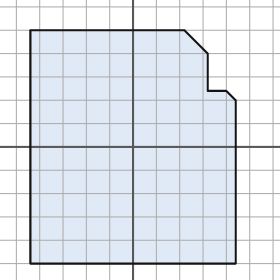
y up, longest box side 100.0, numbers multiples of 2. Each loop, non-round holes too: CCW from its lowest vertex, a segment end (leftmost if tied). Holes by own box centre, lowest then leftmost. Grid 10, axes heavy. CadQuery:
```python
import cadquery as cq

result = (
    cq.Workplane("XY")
    .moveTo(-44.0, -50.0)
    .lineTo(44.0, -50.0)
    .lineTo(44.0, 20.0)
    .lineTo(40.0, 24.0)
    .lineTo(32.0, 24.0)
    .lineTo(32.0, 40.0)
    .lineTo(22.0, 50.0)
    .lineTo(-44.0, 50.0)
    .close()
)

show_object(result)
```